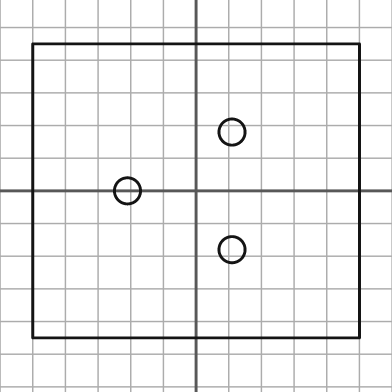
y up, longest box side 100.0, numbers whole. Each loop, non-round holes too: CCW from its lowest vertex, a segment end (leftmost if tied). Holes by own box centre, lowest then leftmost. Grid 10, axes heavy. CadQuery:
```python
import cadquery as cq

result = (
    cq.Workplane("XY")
    .moveTo(-50.0, -45.0)
    .lineTo(50.0, -45.0)
    .lineTo(50.0, 45.0)
    .lineTo(-50.0, 45.0)
    .close()
    .moveTo(11.0, -18.0)
    .circle(4.0)
    .moveTo(-21.0, 0.0)
    .circle(4.0)
    .moveTo(11.0, 18.0)
    .circle(4.0)
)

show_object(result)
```